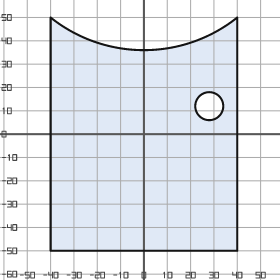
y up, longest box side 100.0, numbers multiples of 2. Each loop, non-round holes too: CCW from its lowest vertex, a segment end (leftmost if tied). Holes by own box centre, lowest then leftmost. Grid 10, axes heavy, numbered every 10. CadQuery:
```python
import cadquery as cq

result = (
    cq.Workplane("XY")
    .moveTo(-40.0, -50.0)
    .lineTo(40.0, -50.0)
    .lineTo(40.0, 50.0)
    .threePointArc((0.0, 36.0), (-40.0, 50.0))
    .close()
    .moveTo(28.0, 12.0)
    .circle(6.0)
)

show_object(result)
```